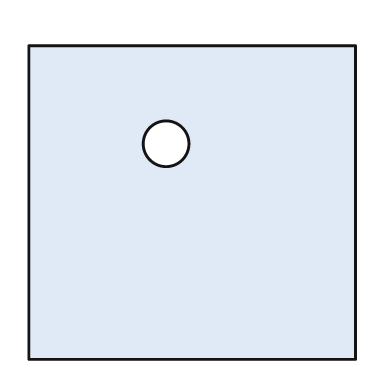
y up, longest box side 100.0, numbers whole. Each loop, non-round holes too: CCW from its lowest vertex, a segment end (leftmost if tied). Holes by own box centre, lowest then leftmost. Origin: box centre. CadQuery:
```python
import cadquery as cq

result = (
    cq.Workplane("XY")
    .moveTo(-50.0, -48.0)
    .lineTo(50.0, -48.0)
    .lineTo(50.0, 48.0)
    .lineTo(-50.0, 48.0)
    .close()
    .moveTo(-8.0, 18.0)
    .circle(7.0)
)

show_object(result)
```